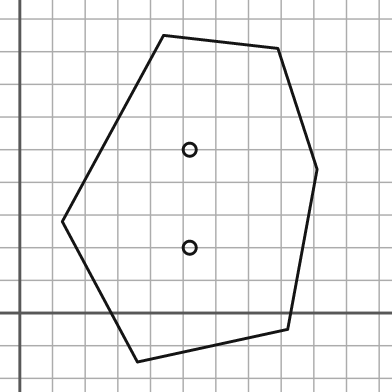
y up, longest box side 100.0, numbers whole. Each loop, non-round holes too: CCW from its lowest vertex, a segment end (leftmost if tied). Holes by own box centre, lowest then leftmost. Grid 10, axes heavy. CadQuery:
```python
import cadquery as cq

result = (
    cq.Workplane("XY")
    .moveTo(36.0, -15.0)
    .lineTo(82.0, -5.0)
    .lineTo(91.0, 44.0)
    .lineTo(79.0, 81.0)
    .lineTo(44.0, 85.0)
    .lineTo(13.0, 28.0)
    .close()
    .moveTo(52.0, 20.0)
    .circle(2.0)
    .moveTo(52.0, 50.0)
    .circle(2.0)
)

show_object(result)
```